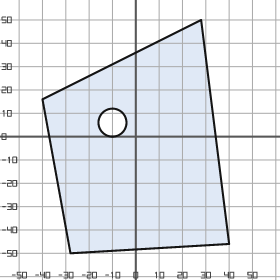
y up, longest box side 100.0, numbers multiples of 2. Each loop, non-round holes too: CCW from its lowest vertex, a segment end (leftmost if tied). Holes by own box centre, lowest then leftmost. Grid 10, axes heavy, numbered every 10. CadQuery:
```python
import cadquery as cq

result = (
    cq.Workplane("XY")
    .moveTo(-28.0, -50.0)
    .lineTo(40.0, -46.0)
    .lineTo(28.0, 50.0)
    .lineTo(-40.0, 16.0)
    .close()
    .moveTo(-10.0, 6.0)
    .circle(6.0)
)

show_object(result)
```